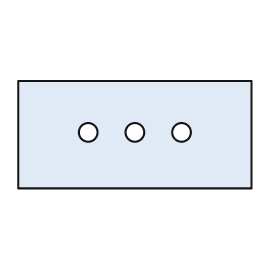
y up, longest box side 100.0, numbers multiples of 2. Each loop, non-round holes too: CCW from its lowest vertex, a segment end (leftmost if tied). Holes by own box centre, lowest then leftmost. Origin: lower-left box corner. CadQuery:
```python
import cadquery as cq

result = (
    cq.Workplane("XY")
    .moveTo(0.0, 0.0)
    .lineTo(100.0, 0.0)
    .lineTo(100.0, 46.0)
    .lineTo(0.0, 46.0)
    .close()
    .moveTo(30.0, 24.0)
    .circle(4.0)
    .moveTo(50.0, 24.0)
    .circle(4.0)
    .moveTo(70.0, 24.0)
    .circle(4.0)
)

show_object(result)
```